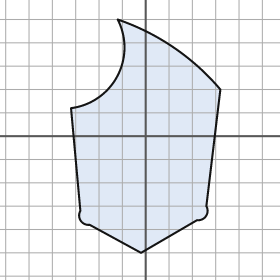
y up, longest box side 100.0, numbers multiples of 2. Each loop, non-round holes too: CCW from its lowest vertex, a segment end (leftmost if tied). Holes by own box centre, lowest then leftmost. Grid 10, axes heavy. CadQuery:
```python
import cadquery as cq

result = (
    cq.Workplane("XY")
    .moveTo(-2.0, -50.0)
    .lineTo(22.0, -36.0)
    .threePointArc((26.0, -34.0), (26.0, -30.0))
    .lineTo(32.0, 20.0)
    .threePointArc((12.0, 38.0), (-12.0, 50.0))
    .threePointArc((-12.0, 26.0), (-32.0, 12.0))
    .lineTo(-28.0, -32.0)
    .threePointArc((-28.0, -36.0), (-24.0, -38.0))
    .close()
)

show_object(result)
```